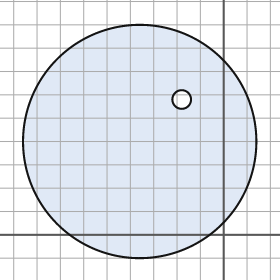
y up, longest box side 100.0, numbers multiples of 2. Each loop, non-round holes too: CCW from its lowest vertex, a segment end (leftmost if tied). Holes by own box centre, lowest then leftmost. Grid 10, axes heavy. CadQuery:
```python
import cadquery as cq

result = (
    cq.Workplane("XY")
    .moveTo(-36.0, 40.0)
    .circle(50.0)
    .moveTo(-18.0, 58.0)
    .circle(4.0)
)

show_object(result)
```